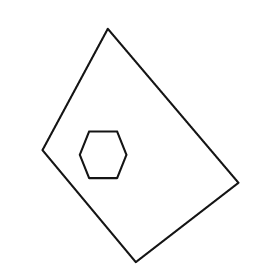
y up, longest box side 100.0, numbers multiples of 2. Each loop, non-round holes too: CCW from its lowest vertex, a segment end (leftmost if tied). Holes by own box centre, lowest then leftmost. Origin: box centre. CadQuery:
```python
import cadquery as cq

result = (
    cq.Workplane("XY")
    .moveTo(-2.0, -50.0)
    .lineTo(42.0, -16.0)
    .lineTo(-14.0, 50.0)
    .lineTo(-42.0, -2.0)
    .close()
    .moveTo(-22.0, -14.0)
    .lineTo(-10.0, -14.0)
    .lineTo(-6.0, -4.0)
    .lineTo(-10.0, 6.0)
    .lineTo(-22.0, 6.0)
    .lineTo(-26.0, -4.0)
    .close()
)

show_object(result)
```